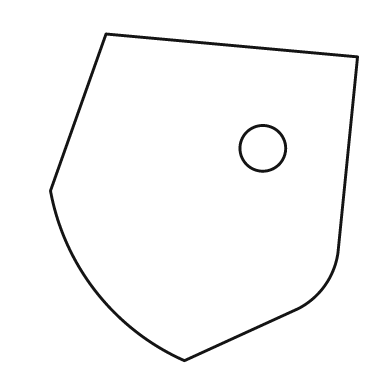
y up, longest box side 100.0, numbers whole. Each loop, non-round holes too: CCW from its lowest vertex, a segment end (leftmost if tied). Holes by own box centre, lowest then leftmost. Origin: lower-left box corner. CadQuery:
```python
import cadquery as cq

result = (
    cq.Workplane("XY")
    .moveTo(41.0, 0.0)
    .lineTo(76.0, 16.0)
    .threePointArc((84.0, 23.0), (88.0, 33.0))
    .lineTo(94.0, 93.0)
    .lineTo(17.0, 100.0)
    .lineTo(0.0, 52.0)
    .threePointArc((14.0, 21.0), (41.0, 0.0))
    .close()
    .moveTo(65.0, 65.0)
    .circle(7.0)
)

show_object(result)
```